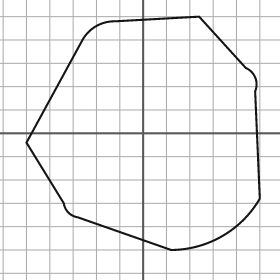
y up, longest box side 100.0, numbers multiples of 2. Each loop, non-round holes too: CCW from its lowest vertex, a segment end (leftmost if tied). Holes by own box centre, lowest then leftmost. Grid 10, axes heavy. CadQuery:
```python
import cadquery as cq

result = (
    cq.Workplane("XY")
    .moveTo(12.0, -50.0)
    .threePointArc((34.0, -44.0), (50.0, -28.0))
    .lineTo(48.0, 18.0)
    .threePointArc((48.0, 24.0), (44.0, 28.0))
    .lineTo(24.0, 50.0)
    .lineTo(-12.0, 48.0)
    .threePointArc((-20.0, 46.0), (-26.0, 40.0))
    .lineTo(-50.0, -4.0)
    .lineTo(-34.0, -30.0)
    .threePointArc((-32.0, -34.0), (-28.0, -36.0))
    .close()
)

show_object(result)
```